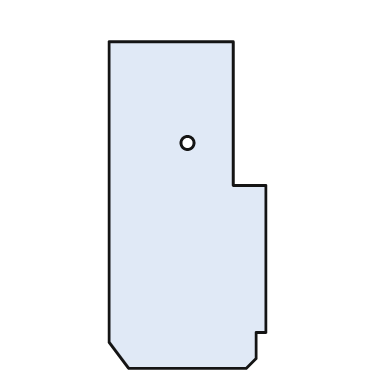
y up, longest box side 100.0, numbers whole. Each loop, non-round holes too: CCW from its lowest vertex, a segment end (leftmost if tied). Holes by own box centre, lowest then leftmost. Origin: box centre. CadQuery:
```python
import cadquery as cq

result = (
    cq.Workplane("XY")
    .moveTo(-18.0, -50.0)
    .lineTo(18.0, -50.0)
    .lineTo(21.0, -47.0)
    .lineTo(21.0, -39.0)
    .lineTo(24.0, -39.0)
    .lineTo(24.0, 6.0)
    .lineTo(14.0, 6.0)
    .lineTo(14.0, 50.0)
    .lineTo(-24.0, 50.0)
    .lineTo(-24.0, -42.0)
    .close()
    .moveTo(0.0, 19.0)
    .circle(2.0)
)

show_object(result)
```